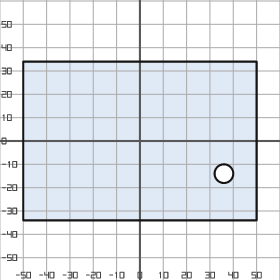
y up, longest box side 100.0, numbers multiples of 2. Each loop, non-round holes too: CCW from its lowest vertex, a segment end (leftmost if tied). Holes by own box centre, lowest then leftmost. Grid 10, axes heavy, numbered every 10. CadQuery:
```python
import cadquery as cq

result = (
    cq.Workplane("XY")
    .moveTo(-50.0, -34.0)
    .lineTo(50.0, -34.0)
    .lineTo(50.0, 34.0)
    .lineTo(-50.0, 34.0)
    .close()
    .moveTo(36.0, -14.0)
    .circle(4.0)
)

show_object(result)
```